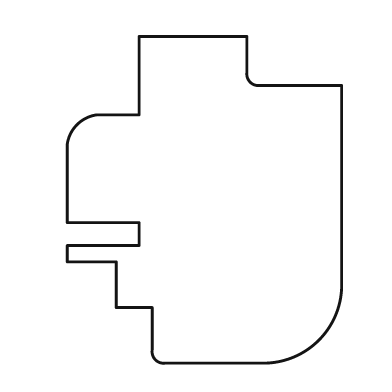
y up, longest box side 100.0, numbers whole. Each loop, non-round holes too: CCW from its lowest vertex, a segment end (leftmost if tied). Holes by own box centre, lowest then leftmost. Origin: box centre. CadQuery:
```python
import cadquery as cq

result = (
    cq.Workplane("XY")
    .moveTo(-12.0, -50.0)
    .lineTo(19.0, -50.0)
    .threePointArc((35.0, -43.0), (42.0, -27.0))
    .lineTo(42.0, 35.0)
    .lineTo(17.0, 35.0)
    .threePointArc((14.0, 36.0), (13.0, 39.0))
    .lineTo(13.0, 50.0)
    .lineTo(-20.0, 50.0)
    .lineTo(-20.0, 26.0)
    .lineTo(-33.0, 26.0)
    .threePointArc((-39.0, 23.0), (-42.0, 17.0))
    .lineTo(-42.0, -7.0)
    .lineTo(-20.0, -7.0)
    .lineTo(-20.0, -14.0)
    .lineTo(-42.0, -14.0)
    .lineTo(-42.0, -19.0)
    .lineTo(-27.0, -19.0)
    .lineTo(-27.0, -33.0)
    .lineTo(-16.0, -33.0)
    .lineTo(-16.0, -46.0)
    .threePointArc((-15.0, -49.0), (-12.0, -50.0))
    .close()
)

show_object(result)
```